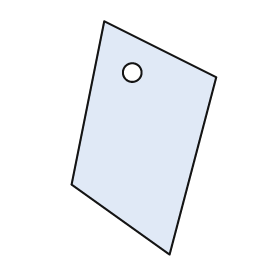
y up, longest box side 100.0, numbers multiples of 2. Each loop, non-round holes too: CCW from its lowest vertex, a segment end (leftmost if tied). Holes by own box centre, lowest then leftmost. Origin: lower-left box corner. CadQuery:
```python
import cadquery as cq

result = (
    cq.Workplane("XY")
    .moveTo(42.0, 0.0)
    .lineTo(62.0, 76.0)
    .lineTo(14.0, 100.0)
    .lineTo(0.0, 30.0)
    .close()
    .moveTo(26.0, 78.0)
    .circle(4.0)
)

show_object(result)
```